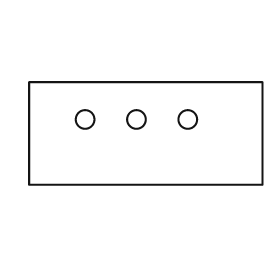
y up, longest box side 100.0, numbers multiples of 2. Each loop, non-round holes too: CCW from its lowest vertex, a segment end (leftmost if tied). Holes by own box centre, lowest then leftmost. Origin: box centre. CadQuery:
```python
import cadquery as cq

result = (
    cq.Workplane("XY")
    .moveTo(-50.0, -22.0)
    .lineTo(50.0, -22.0)
    .lineTo(50.0, 22.0)
    .lineTo(-50.0, 22.0)
    .close()
    .moveTo(-26.0, 6.0)
    .circle(4.0)
    .moveTo(-4.0, 6.0)
    .circle(4.0)
    .moveTo(18.0, 6.0)
    .circle(4.0)
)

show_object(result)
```